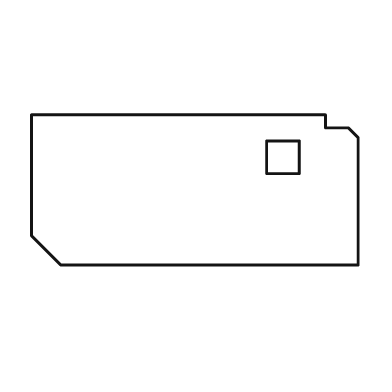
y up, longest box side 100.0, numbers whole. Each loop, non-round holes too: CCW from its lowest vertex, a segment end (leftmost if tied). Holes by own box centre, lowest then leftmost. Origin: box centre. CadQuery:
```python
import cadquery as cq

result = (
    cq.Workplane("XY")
    .moveTo(-41.0, -23.0)
    .lineTo(50.0, -23.0)
    .lineTo(50.0, 16.0)
    .lineTo(47.0, 19.0)
    .lineTo(40.0, 19.0)
    .lineTo(40.0, 23.0)
    .lineTo(-50.0, 23.0)
    .lineTo(-50.0, -14.0)
    .close()
    .moveTo(22.0, 5.0)
    .lineTo(32.0, 5.0)
    .lineTo(32.0, 15.0)
    .lineTo(22.0, 15.0)
    .close()
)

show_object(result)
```